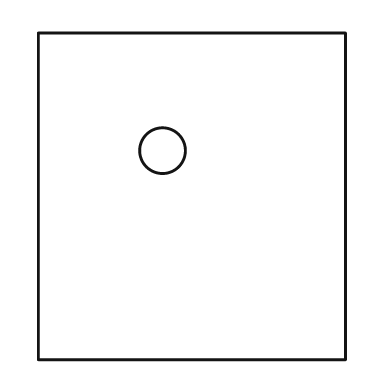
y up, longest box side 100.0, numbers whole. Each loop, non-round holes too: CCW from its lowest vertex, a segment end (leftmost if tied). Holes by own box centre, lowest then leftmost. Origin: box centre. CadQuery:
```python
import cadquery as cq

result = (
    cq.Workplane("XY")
    .moveTo(-47.0, -50.0)
    .lineTo(47.0, -50.0)
    .lineTo(47.0, 50.0)
    .lineTo(-47.0, 50.0)
    .close()
    .moveTo(-9.0, 14.0)
    .circle(7.0)
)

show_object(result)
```